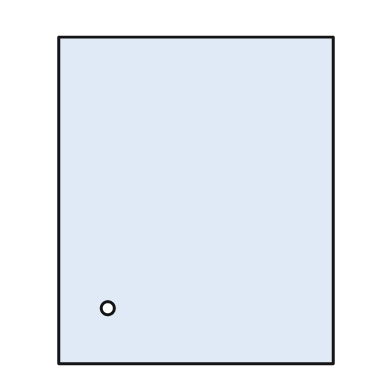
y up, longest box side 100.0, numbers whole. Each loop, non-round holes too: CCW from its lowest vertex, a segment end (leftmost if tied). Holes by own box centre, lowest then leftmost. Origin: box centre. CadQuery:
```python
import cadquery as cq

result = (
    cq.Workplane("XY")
    .moveTo(-42.0, -50.0)
    .lineTo(42.0, -50.0)
    .lineTo(42.0, 50.0)
    .lineTo(-42.0, 50.0)
    .close()
    .moveTo(-27.0, -33.0)
    .circle(2.0)
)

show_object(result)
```